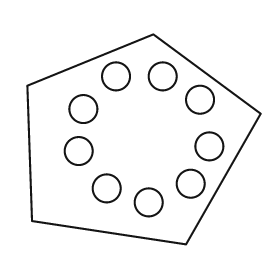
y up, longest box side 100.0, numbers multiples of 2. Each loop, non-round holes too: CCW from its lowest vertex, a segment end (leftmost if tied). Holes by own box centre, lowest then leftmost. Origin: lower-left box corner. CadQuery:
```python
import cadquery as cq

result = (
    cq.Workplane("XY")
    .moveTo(68.0, 0.0)
    .lineTo(100.0, 56.0)
    .lineTo(54.0, 90.0)
    .lineTo(0.0, 68.0)
    .lineTo(2.0, 10.0)
    .close()
    .moveTo(52.0, 18.0)
    .circle(6.0)
    .moveTo(34.0, 24.0)
    .circle(6.0)
    .moveTo(70.0, 26.0)
    .circle(6.0)
    .moveTo(22.0, 40.0)
    .circle(6.0)
    .moveTo(78.0, 42.0)
    .circle(6.0)
    .moveTo(24.0, 58.0)
    .circle(6.0)
    .moveTo(74.0, 62.0)
    .circle(6.0)
    .moveTo(38.0, 72.0)
    .circle(6.0)
    .moveTo(58.0, 72.0)
    .circle(6.0)
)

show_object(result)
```